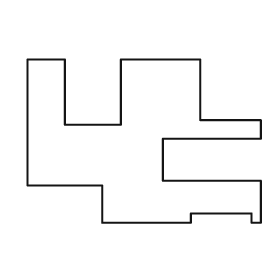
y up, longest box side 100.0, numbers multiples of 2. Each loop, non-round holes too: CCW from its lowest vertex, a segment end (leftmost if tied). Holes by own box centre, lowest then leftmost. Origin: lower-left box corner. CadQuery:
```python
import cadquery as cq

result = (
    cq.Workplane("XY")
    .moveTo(32.0, 0.0)
    .lineTo(70.0, 0.0)
    .lineTo(70.0, 4.0)
    .lineTo(96.0, 4.0)
    .lineTo(96.0, 0.0)
    .lineTo(100.0, 0.0)
    .lineTo(100.0, 18.0)
    .lineTo(58.0, 18.0)
    .lineTo(58.0, 36.0)
    .lineTo(100.0, 36.0)
    .lineTo(100.0, 44.0)
    .lineTo(74.0, 44.0)
    .lineTo(74.0, 70.0)
    .lineTo(40.0, 70.0)
    .lineTo(40.0, 42.0)
    .lineTo(16.0, 42.0)
    .lineTo(16.0, 70.0)
    .lineTo(0.0, 70.0)
    .lineTo(0.0, 16.0)
    .lineTo(32.0, 16.0)
    .close()
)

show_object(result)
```